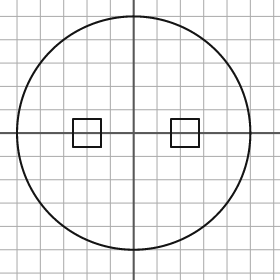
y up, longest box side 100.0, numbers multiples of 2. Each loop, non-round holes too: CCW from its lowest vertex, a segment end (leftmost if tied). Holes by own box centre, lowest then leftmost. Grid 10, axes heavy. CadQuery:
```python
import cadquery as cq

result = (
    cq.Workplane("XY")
    .moveTo(0.0, 0.0)
    .circle(50.0)
    .moveTo(-26.0, -6.0)
    .lineTo(-14.0, -6.0)
    .lineTo(-14.0, 6.0)
    .lineTo(-26.0, 6.0)
    .close()
    .moveTo(16.0, -6.0)
    .lineTo(28.0, -6.0)
    .lineTo(28.0, 6.0)
    .lineTo(16.0, 6.0)
    .close()
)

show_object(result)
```